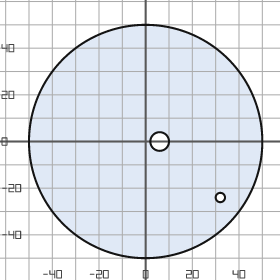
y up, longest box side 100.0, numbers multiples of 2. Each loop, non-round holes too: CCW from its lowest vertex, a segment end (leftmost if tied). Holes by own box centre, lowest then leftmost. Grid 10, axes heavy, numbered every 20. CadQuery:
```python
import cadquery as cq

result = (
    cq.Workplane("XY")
    .moveTo(0.0, 0.0)
    .circle(50.0)
    .moveTo(32.0, -24.0)
    .circle(2.0)
    .moveTo(6.0, 0.0)
    .circle(4.0)
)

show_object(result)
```